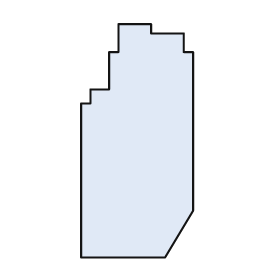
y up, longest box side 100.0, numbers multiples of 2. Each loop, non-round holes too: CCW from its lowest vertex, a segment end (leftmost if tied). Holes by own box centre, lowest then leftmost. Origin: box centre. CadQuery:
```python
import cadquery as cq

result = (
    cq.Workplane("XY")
    .moveTo(-24.0, -50.0)
    .lineTo(12.0, -50.0)
    .lineTo(24.0, -30.0)
    .lineTo(24.0, 38.0)
    .lineTo(20.0, 38.0)
    .lineTo(20.0, 46.0)
    .lineTo(6.0, 46.0)
    .lineTo(6.0, 50.0)
    .lineTo(-8.0, 50.0)
    .lineTo(-8.0, 38.0)
    .lineTo(-12.0, 38.0)
    .lineTo(-12.0, 22.0)
    .lineTo(-20.0, 22.0)
    .lineTo(-20.0, 16.0)
    .lineTo(-24.0, 16.0)
    .close()
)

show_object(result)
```